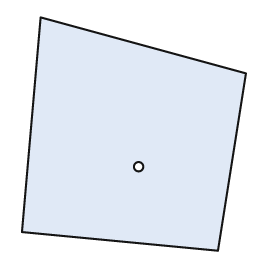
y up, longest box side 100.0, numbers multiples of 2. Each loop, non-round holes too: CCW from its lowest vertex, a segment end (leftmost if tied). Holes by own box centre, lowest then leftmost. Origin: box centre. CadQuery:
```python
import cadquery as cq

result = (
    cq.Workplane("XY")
    .moveTo(36.0, -50.0)
    .lineTo(48.0, 26.0)
    .lineTo(-40.0, 50.0)
    .lineTo(-48.0, -42.0)
    .close()
    .moveTo(2.0, -14.0)
    .circle(2.0)
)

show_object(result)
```